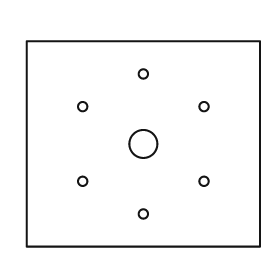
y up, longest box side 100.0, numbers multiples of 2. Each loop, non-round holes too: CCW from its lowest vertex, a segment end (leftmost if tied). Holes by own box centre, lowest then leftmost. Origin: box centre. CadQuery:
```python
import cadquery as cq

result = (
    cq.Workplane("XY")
    .moveTo(-50.0, -44.0)
    .lineTo(50.0, -44.0)
    .lineTo(50.0, 44.0)
    .lineTo(-50.0, 44.0)
    .close()
    .moveTo(0.0, -30.0)
    .circle(2.0)
    .moveTo(-26.0, -16.0)
    .circle(2.0)
    .moveTo(26.0, -16.0)
    .circle(2.0)
    .moveTo(0.0, 0.0)
    .circle(6.0)
    .moveTo(-26.0, 16.0)
    .circle(2.0)
    .moveTo(26.0, 16.0)
    .circle(2.0)
    .moveTo(0.0, 30.0)
    .circle(2.0)
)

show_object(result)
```